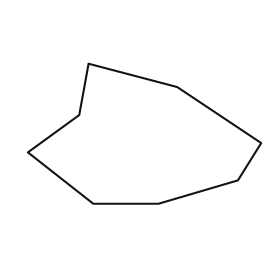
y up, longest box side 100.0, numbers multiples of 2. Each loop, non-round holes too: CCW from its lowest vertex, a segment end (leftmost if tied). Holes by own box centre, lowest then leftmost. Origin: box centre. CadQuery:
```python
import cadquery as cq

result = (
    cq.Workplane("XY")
    .moveTo(-22.0, -30.0)
    .lineTo(6.0, -30.0)
    .lineTo(40.0, -20.0)
    .lineTo(50.0, -4.0)
    .lineTo(14.0, 20.0)
    .lineTo(-24.0, 30.0)
    .lineTo(-28.0, 8.0)
    .lineTo(-50.0, -8.0)
    .close()
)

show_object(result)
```